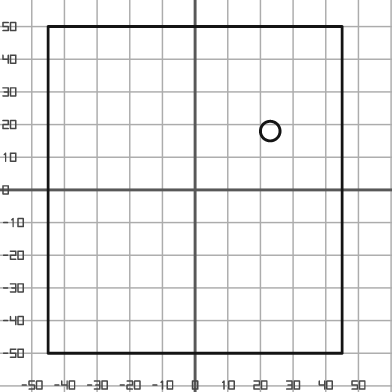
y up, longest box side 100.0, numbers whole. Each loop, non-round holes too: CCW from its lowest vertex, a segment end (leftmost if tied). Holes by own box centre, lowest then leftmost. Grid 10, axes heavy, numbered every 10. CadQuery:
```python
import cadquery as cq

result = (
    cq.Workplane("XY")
    .moveTo(-45.0, -50.0)
    .lineTo(45.0, -50.0)
    .lineTo(45.0, 50.0)
    .lineTo(-45.0, 50.0)
    .close()
    .moveTo(23.0, 18.0)
    .circle(3.0)
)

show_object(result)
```